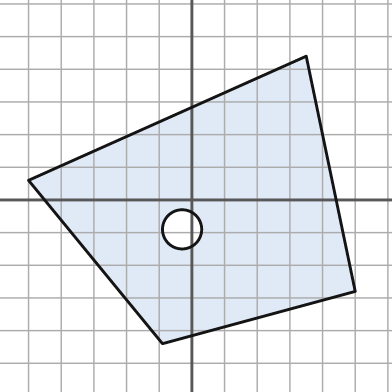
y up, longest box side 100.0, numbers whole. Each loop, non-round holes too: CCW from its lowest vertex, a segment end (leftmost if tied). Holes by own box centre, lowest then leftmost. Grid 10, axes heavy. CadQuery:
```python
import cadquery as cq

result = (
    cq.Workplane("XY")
    .moveTo(-9.0, -44.0)
    .lineTo(50.0, -28.0)
    .lineTo(35.0, 44.0)
    .lineTo(-50.0, 6.0)
    .close()
    .moveTo(-3.0, -9.0)
    .circle(6.0)
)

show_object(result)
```